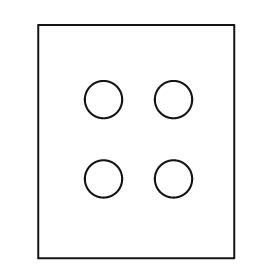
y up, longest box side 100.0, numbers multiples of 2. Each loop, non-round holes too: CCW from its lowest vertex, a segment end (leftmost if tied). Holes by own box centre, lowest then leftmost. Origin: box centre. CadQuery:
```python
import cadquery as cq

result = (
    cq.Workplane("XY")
    .moveTo(-42.0, -50.0)
    .lineTo(42.0, -50.0)
    .lineTo(42.0, 50.0)
    .lineTo(-42.0, 50.0)
    .close()
    .moveTo(-14.0, -16.0)
    .circle(8.0)
    .moveTo(16.0, -16.0)
    .circle(8.0)
    .moveTo(-14.0, 18.0)
    .circle(8.0)
    .moveTo(16.0, 18.0)
    .circle(8.0)
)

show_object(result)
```